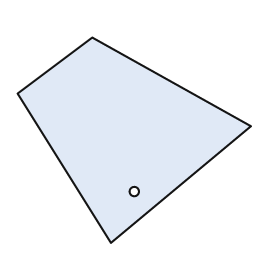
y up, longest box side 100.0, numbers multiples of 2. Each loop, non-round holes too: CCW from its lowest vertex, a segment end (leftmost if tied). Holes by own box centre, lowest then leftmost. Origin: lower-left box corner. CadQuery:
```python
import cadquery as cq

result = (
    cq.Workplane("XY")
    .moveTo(40.0, 0.0)
    .lineTo(100.0, 50.0)
    .lineTo(32.0, 88.0)
    .lineTo(0.0, 64.0)
    .close()
    .moveTo(50.0, 22.0)
    .circle(2.0)
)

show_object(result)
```